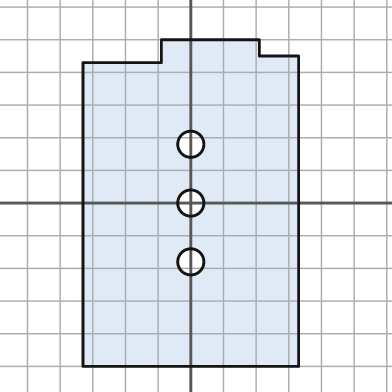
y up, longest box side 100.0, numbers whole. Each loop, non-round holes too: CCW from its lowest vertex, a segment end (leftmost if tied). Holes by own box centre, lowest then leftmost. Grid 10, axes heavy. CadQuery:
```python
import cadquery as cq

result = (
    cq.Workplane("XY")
    .moveTo(-33.0, -50.0)
    .lineTo(33.0, -50.0)
    .lineTo(33.0, 45.0)
    .lineTo(21.0, 45.0)
    .lineTo(21.0, 50.0)
    .lineTo(-9.0, 50.0)
    .lineTo(-9.0, 43.0)
    .lineTo(-33.0, 43.0)
    .close()
    .moveTo(0.0, -18.0)
    .circle(4.0)
    .moveTo(0.0, 0.0)
    .circle(4.0)
    .moveTo(0.0, 18.0)
    .circle(4.0)
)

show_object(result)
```